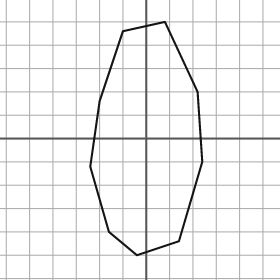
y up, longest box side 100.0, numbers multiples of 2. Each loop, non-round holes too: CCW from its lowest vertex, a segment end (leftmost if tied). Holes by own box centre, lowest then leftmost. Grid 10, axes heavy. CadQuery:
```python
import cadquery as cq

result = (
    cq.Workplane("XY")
    .moveTo(-4.0, -50.0)
    .lineTo(14.0, -44.0)
    .lineTo(24.0, -10.0)
    .lineTo(22.0, 20.0)
    .lineTo(8.0, 50.0)
    .lineTo(-10.0, 46.0)
    .lineTo(-20.0, 16.0)
    .lineTo(-24.0, -12.0)
    .lineTo(-16.0, -40.0)
    .close()
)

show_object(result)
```